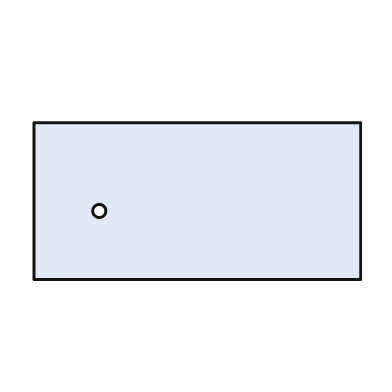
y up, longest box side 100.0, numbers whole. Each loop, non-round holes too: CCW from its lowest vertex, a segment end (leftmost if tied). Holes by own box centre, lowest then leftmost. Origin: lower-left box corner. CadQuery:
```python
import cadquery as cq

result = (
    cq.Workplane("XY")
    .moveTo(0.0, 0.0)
    .lineTo(100.0, 0.0)
    .lineTo(100.0, 48.0)
    .lineTo(0.0, 48.0)
    .close()
    .moveTo(20.0, 21.0)
    .circle(2.0)
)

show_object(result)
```